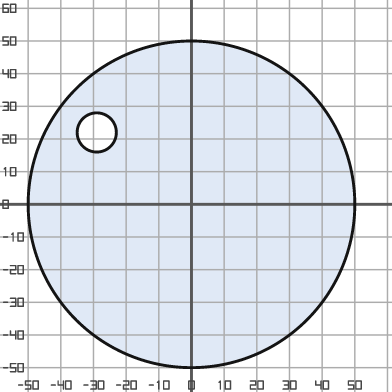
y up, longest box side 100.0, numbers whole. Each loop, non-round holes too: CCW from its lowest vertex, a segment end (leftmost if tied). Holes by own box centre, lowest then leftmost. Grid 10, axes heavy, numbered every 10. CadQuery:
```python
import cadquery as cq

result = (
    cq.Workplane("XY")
    .moveTo(0.0, 0.0)
    .circle(50.0)
    .moveTo(-29.0, 22.0)
    .circle(6.0)
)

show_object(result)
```